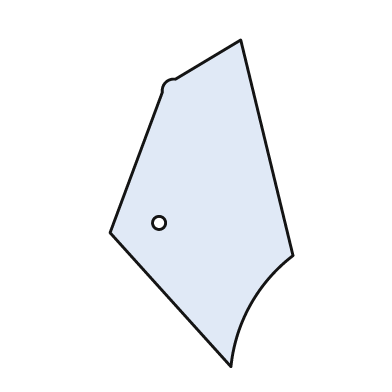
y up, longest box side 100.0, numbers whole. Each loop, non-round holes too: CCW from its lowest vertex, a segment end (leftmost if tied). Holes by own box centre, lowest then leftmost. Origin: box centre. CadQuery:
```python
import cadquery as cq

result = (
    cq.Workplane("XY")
    .moveTo(9.0, -50.0)
    .threePointArc((15.0, -31.0), (28.0, -16.0))
    .lineTo(12.0, 50.0)
    .lineTo(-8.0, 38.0)
    .threePointArc((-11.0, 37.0), (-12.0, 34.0))
    .lineTo(-28.0, -9.0)
    .close()
    .moveTo(-13.0, -6.0)
    .circle(2.0)
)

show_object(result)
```